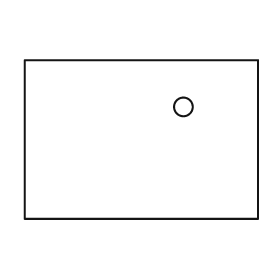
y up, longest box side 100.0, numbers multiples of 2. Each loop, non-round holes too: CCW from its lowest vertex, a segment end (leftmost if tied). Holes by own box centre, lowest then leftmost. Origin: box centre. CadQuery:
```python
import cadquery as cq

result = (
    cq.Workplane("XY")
    .moveTo(-50.0, -34.0)
    .lineTo(50.0, -34.0)
    .lineTo(50.0, 34.0)
    .lineTo(-50.0, 34.0)
    .close()
    .moveTo(18.0, 14.0)
    .circle(4.0)
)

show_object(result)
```